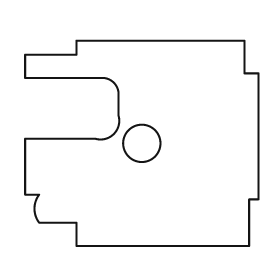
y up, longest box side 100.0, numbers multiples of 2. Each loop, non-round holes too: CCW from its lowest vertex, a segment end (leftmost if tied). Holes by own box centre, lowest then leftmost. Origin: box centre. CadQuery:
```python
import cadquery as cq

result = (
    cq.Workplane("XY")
    .moveTo(-28.0, -44.0)
    .lineTo(46.0, -44.0)
    .lineTo(46.0, -24.0)
    .lineTo(50.0, -24.0)
    .lineTo(50.0, 30.0)
    .lineTo(44.0, 30.0)
    .lineTo(44.0, 44.0)
    .lineTo(-28.0, 44.0)
    .lineTo(-28.0, 38.0)
    .lineTo(-50.0, 38.0)
    .lineTo(-50.0, 28.0)
    .lineTo(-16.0, 28.0)
    .threePointArc((-12.0, 26.0), (-10.0, 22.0))
    .lineTo(-10.0, 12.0)
    .threePointArc((-12.0, 4.0), (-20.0, 2.0))
    .lineTo(-50.0, 2.0)
    .lineTo(-50.0, -22.0)
    .lineTo(-44.0, -22.0)
    .threePointArc((-46.0, -28.0), (-44.0, -34.0))
    .lineTo(-28.0, -34.0)
    .close()
    .moveTo(0.0, 0.0)
    .circle(8.0)
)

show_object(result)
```